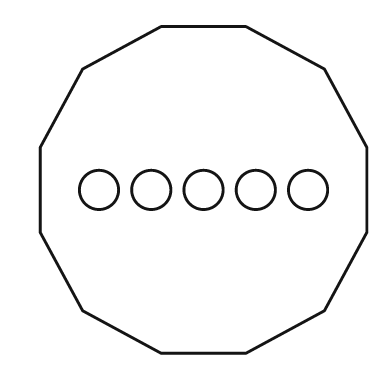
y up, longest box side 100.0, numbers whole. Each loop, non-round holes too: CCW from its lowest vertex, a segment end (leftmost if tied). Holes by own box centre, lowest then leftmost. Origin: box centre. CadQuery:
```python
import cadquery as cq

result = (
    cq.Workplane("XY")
    .moveTo(-13.0, -50.0)
    .lineTo(13.0, -50.0)
    .lineTo(37.0, -37.0)
    .lineTo(50.0, -13.0)
    .lineTo(50.0, 13.0)
    .lineTo(37.0, 37.0)
    .lineTo(13.0, 50.0)
    .lineTo(-13.0, 50.0)
    .lineTo(-37.0, 37.0)
    .lineTo(-50.0, 13.0)
    .lineTo(-50.0, -13.0)
    .lineTo(-37.0, -37.0)
    .close()
    .moveTo(-32.0, 0.0)
    .circle(6.0)
    .moveTo(-16.0, 0.0)
    .circle(6.0)
    .moveTo(0.0, 0.0)
    .circle(6.0)
    .moveTo(16.0, 0.0)
    .circle(6.0)
    .moveTo(32.0, 0.0)
    .circle(6.0)
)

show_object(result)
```